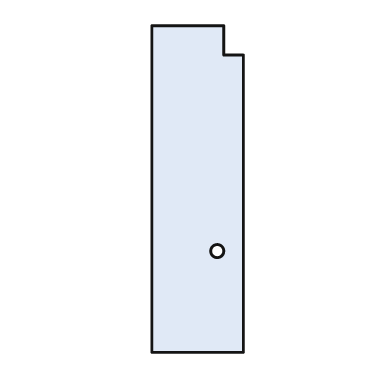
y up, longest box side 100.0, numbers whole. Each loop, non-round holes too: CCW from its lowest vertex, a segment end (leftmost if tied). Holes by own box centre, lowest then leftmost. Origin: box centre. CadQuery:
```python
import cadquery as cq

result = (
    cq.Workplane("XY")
    .moveTo(-14.0, -50.0)
    .lineTo(14.0, -50.0)
    .lineTo(14.0, 41.0)
    .lineTo(8.0, 41.0)
    .lineTo(8.0, 50.0)
    .lineTo(-14.0, 50.0)
    .close()
    .moveTo(6.0, -19.0)
    .circle(2.0)
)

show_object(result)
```